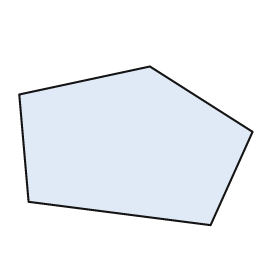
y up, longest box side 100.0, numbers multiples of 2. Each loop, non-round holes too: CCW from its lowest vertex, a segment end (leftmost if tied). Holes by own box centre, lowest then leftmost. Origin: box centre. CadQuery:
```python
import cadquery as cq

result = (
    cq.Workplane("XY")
    .moveTo(32.0, -34.0)
    .lineTo(50.0, 6.0)
    .lineTo(6.0, 34.0)
    .lineTo(-50.0, 22.0)
    .lineTo(-46.0, -24.0)
    .close()
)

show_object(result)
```